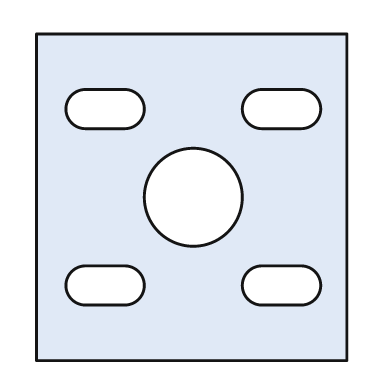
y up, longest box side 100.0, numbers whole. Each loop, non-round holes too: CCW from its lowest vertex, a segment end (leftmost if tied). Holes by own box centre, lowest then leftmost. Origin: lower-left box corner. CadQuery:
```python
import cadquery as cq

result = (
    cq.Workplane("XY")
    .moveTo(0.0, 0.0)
    .lineTo(95.0, 0.0)
    .lineTo(95.0, 100.0)
    .lineTo(0.0, 100.0)
    .close()
    .moveTo(15.0, 17.0)
    .lineTo(27.0, 17.0)
    .threePointArc((33.0, 23.0), (27.0, 29.0))
    .lineTo(15.0, 29.0)
    .threePointArc((9.0, 23.0), (15.0, 17.0))
    .close()
    .moveTo(69.0, 17.0)
    .lineTo(81.0, 17.0)
    .threePointArc((87.0, 23.0), (81.0, 29.0))
    .lineTo(69.0, 29.0)
    .threePointArc((63.0, 23.0), (69.0, 17.0))
    .close()
    .moveTo(48.0, 50.0)
    .circle(15.0)
    .moveTo(15.0, 71.0)
    .lineTo(27.0, 71.0)
    .threePointArc((33.0, 77.0), (27.0, 83.0))
    .lineTo(15.0, 83.0)
    .threePointArc((9.0, 77.0), (15.0, 71.0))
    .close()
    .moveTo(69.0, 71.0)
    .lineTo(81.0, 71.0)
    .threePointArc((87.0, 77.0), (81.0, 83.0))
    .lineTo(69.0, 83.0)
    .threePointArc((63.0, 77.0), (69.0, 71.0))
    .close()
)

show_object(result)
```